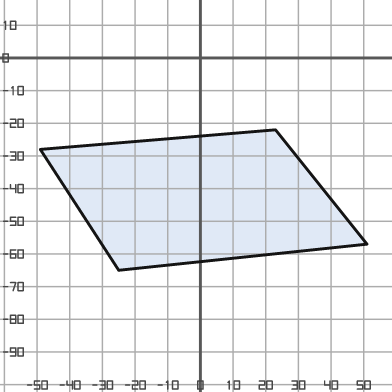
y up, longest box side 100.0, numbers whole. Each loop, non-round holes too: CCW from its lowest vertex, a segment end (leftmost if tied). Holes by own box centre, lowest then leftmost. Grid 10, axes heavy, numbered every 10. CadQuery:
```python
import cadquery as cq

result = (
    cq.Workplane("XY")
    .moveTo(-25.0, -65.0)
    .lineTo(51.0, -57.0)
    .lineTo(23.0, -22.0)
    .lineTo(-49.0, -28.0)
    .close()
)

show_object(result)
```